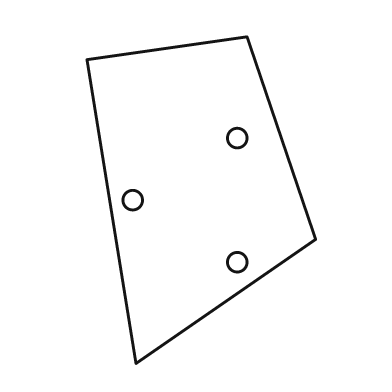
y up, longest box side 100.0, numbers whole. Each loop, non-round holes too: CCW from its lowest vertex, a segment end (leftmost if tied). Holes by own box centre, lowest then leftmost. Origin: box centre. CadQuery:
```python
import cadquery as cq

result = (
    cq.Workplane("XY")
    .moveTo(-20.0, -50.0)
    .lineTo(35.0, -12.0)
    .lineTo(14.0, 50.0)
    .lineTo(-35.0, 43.0)
    .close()
    .moveTo(11.0, -19.0)
    .circle(3.0)
    .moveTo(-21.0, 0.0)
    .circle(3.0)
    .moveTo(11.0, 19.0)
    .circle(3.0)
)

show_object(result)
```